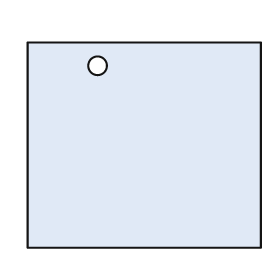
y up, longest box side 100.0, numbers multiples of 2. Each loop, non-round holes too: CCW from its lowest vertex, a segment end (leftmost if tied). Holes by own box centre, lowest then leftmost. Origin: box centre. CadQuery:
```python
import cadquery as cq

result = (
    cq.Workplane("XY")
    .moveTo(-50.0, -44.0)
    .lineTo(50.0, -44.0)
    .lineTo(50.0, 44.0)
    .lineTo(-50.0, 44.0)
    .close()
    .moveTo(-20.0, 34.0)
    .circle(4.0)
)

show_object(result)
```